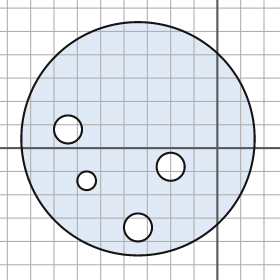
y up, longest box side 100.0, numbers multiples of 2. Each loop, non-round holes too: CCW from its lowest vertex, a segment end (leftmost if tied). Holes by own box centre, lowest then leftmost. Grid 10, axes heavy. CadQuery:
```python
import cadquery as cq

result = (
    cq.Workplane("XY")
    .moveTo(-34.0, 4.0)
    .circle(50.0)
    .moveTo(-34.0, -34.0)
    .circle(6.0)
    .moveTo(-56.0, -14.0)
    .circle(4.0)
    .moveTo(-20.0, -8.0)
    .circle(6.0)
    .moveTo(-64.0, 8.0)
    .circle(6.0)
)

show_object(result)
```